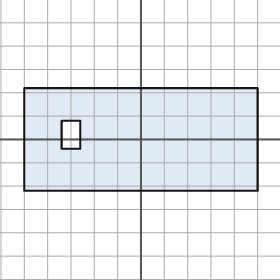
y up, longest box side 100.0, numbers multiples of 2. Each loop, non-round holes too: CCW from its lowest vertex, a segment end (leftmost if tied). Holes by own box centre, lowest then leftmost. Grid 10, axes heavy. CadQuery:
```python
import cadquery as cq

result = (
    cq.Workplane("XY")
    .moveTo(-50.0, -22.0)
    .lineTo(50.0, -22.0)
    .lineTo(50.0, 22.0)
    .lineTo(-50.0, 22.0)
    .close()
    .moveTo(-34.0, -4.0)
    .lineTo(-26.0, -4.0)
    .lineTo(-26.0, 8.0)
    .lineTo(-34.0, 8.0)
    .close()
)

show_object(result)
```